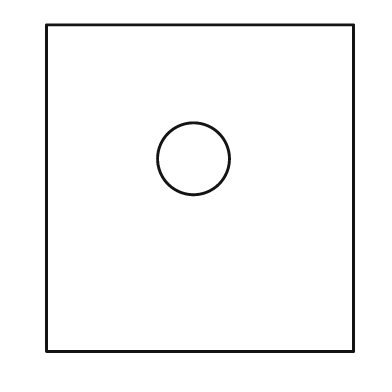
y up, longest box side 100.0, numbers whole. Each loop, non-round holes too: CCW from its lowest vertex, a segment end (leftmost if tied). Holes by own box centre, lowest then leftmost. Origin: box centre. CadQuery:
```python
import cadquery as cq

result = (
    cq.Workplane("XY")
    .moveTo(-47.0, -50.0)
    .lineTo(47.0, -50.0)
    .lineTo(47.0, 50.0)
    .lineTo(-47.0, 50.0)
    .close()
    .moveTo(-2.0, 9.0)
    .circle(11.0)
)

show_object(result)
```